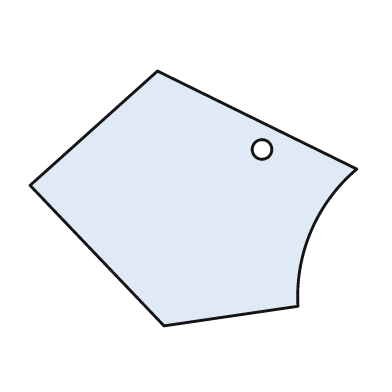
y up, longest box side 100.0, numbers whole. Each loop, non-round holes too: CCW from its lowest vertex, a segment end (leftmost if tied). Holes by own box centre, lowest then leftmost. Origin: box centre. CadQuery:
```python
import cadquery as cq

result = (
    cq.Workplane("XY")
    .moveTo(-9.0, -39.0)
    .lineTo(32.0, -33.0)
    .threePointArc((36.0, -10.0), (50.0, 9.0))
    .lineTo(-11.0, 39.0)
    .lineTo(-50.0, 4.0)
    .close()
    .moveTo(21.0, 15.0)
    .circle(3.0)
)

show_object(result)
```